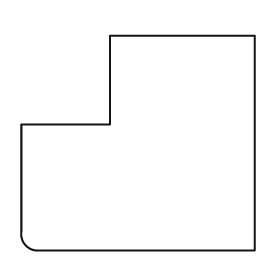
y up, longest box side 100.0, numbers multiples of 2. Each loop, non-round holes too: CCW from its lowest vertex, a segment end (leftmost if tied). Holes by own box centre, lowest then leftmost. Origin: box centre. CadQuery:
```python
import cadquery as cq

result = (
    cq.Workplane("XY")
    .moveTo(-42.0, -46.0)
    .lineTo(50.0, -46.0)
    .lineTo(50.0, 46.0)
    .lineTo(-12.0, 46.0)
    .lineTo(-12.0, 8.0)
    .lineTo(-50.0, 8.0)
    .lineTo(-50.0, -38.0)
    .threePointArc((-48.0, -44.0), (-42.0, -46.0))
    .close()
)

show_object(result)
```